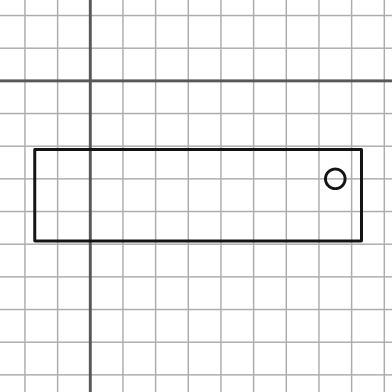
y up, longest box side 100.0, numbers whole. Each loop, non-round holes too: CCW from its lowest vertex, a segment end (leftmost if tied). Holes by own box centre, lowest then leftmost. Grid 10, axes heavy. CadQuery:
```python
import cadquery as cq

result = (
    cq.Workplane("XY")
    .moveTo(-17.0, -49.0)
    .lineTo(83.0, -49.0)
    .lineTo(83.0, -21.0)
    .lineTo(-17.0, -21.0)
    .close()
    .moveTo(75.0, -30.0)
    .circle(3.0)
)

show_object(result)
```